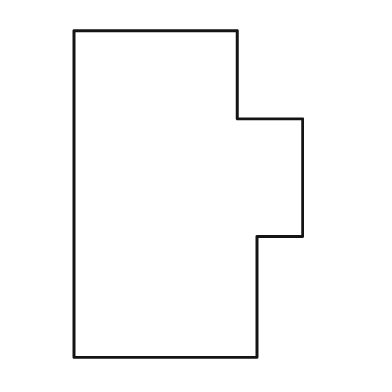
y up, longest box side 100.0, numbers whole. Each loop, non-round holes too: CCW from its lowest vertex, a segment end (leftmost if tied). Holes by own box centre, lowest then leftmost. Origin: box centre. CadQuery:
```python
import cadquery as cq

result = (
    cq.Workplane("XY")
    .moveTo(-35.0, -50.0)
    .lineTo(21.0, -50.0)
    .lineTo(21.0, -13.0)
    .lineTo(35.0, -13.0)
    .lineTo(35.0, 23.0)
    .lineTo(15.0, 23.0)
    .lineTo(15.0, 50.0)
    .lineTo(-35.0, 50.0)
    .close()
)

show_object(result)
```